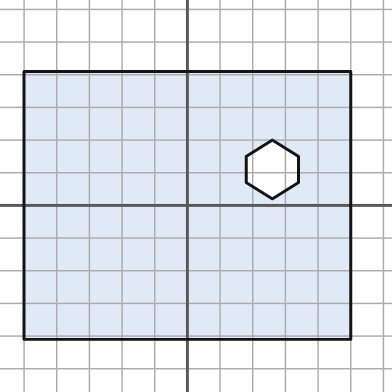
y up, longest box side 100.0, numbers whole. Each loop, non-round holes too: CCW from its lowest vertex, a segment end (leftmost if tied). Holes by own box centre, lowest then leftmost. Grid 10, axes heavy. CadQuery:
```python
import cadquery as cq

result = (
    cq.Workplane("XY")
    .moveTo(-50.0, -41.0)
    .lineTo(50.0, -41.0)
    .lineTo(50.0, 41.0)
    .lineTo(-50.0, 41.0)
    .close()
    .moveTo(26.0, 2.0)
    .lineTo(34.0, 7.0)
    .lineTo(34.0, 15.0)
    .lineTo(26.0, 20.0)
    .lineTo(18.0, 15.0)
    .lineTo(18.0, 7.0)
    .close()
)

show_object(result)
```